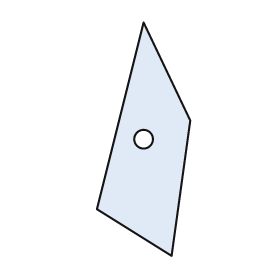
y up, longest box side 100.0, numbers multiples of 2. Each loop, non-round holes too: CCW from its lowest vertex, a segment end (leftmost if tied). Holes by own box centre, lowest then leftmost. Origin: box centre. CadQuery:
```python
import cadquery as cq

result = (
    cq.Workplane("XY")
    .moveTo(12.0, -50.0)
    .lineTo(20.0, 8.0)
    .lineTo(0.0, 50.0)
    .lineTo(-20.0, -30.0)
    .close()
    .moveTo(0.0, 0.0)
    .circle(4.0)
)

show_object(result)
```